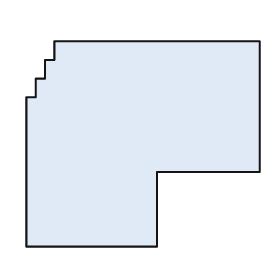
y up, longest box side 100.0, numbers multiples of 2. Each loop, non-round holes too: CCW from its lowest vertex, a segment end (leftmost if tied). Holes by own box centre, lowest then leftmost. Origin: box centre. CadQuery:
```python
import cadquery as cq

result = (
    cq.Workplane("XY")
    .moveTo(-50.0, -44.0)
    .lineTo(6.0, -44.0)
    .lineTo(6.0, -12.0)
    .lineTo(50.0, -12.0)
    .lineTo(50.0, 44.0)
    .lineTo(-38.0, 44.0)
    .lineTo(-38.0, 36.0)
    .lineTo(-42.0, 36.0)
    .lineTo(-42.0, 28.0)
    .lineTo(-46.0, 28.0)
    .lineTo(-46.0, 20.0)
    .lineTo(-50.0, 20.0)
    .close()
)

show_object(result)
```